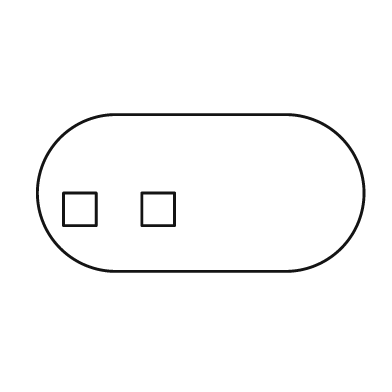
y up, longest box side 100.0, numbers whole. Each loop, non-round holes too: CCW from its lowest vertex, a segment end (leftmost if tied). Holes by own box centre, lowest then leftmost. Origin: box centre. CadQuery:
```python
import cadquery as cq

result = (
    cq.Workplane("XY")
    .moveTo(-26.0, -24.0)
    .lineTo(26.0, -24.0)
    .threePointArc((50.0, 0.0), (26.0, 24.0))
    .lineTo(-26.0, 24.0)
    .threePointArc((-50.0, 0.0), (-26.0, -24.0))
    .close()
    .moveTo(-42.0, -10.0)
    .lineTo(-32.0, -10.0)
    .lineTo(-32.0, 0.0)
    .lineTo(-42.0, 0.0)
    .close()
    .moveTo(-18.0, -10.0)
    .lineTo(-8.0, -10.0)
    .lineTo(-8.0, 0.0)
    .lineTo(-18.0, 0.0)
    .close()
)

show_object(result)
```